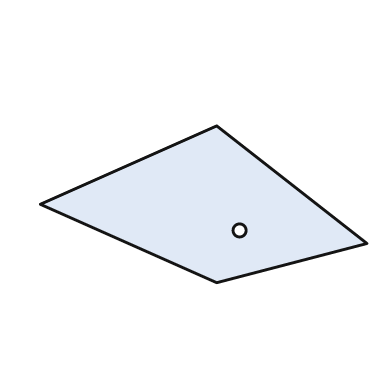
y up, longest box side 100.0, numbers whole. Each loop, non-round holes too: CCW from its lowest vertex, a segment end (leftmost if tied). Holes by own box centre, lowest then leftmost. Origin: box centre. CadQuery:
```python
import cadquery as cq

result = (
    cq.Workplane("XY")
    .moveTo(4.0, -24.0)
    .lineTo(50.0, -12.0)
    .lineTo(4.0, 24.0)
    .lineTo(-50.0, 0.0)
    .close()
    .moveTo(11.0, -8.0)
    .circle(2.0)
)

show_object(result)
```